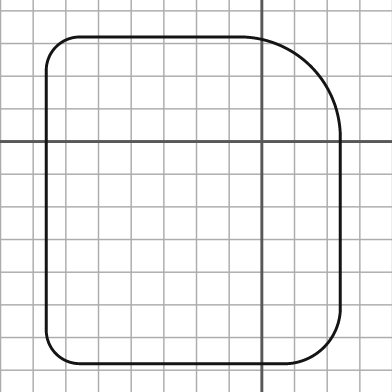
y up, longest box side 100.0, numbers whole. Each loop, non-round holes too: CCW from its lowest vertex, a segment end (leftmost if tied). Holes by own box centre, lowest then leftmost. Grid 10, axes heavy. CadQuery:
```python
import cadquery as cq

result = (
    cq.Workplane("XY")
    .moveTo(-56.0, -68.0)
    .lineTo(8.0, -68.0)
    .threePointArc((19.0, -63.0), (24.0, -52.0))
    .lineTo(24.0, 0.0)
    .threePointArc((15.0, 23.0), (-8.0, 32.0))
    .lineTo(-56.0, 32.0)
    .threePointArc((-63.0, 29.0), (-66.0, 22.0))
    .lineTo(-66.0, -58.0)
    .threePointArc((-63.0, -65.0), (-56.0, -68.0))
    .close()
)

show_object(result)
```